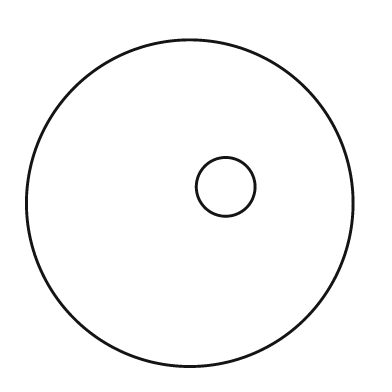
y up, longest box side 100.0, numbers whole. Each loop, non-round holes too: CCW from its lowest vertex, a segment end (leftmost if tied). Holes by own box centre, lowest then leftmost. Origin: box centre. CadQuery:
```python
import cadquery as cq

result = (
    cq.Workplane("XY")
    .moveTo(0.0, 0.0)
    .circle(50.0)
    .moveTo(11.0, 5.0)
    .circle(9.0)
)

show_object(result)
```